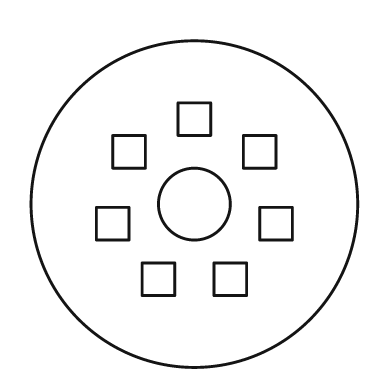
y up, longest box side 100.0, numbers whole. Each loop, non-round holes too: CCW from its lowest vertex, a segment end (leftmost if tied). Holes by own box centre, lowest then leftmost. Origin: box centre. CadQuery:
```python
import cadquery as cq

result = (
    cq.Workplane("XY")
    .moveTo(0.0, 0.0)
    .circle(50.0)
    .moveTo(-16.0, -28.0)
    .lineTo(-6.0, -28.0)
    .lineTo(-6.0, -18.0)
    .lineTo(-16.0, -18.0)
    .close()
    .moveTo(6.0, -28.0)
    .lineTo(16.0, -28.0)
    .lineTo(16.0, -18.0)
    .lineTo(6.0, -18.0)
    .close()
    .moveTo(-30.0, -11.0)
    .lineTo(-20.0, -11.0)
    .lineTo(-20.0, -1.0)
    .lineTo(-30.0, -1.0)
    .close()
    .moveTo(20.0, -11.0)
    .lineTo(30.0, -11.0)
    .lineTo(30.0, -1.0)
    .lineTo(20.0, -1.0)
    .close()
    .moveTo(0.0, 0.0)
    .circle(11.0)
    .moveTo(-25.0, 11.0)
    .lineTo(-15.0, 11.0)
    .lineTo(-15.0, 21.0)
    .lineTo(-25.0, 21.0)
    .close()
    .moveTo(15.0, 11.0)
    .lineTo(25.0, 11.0)
    .lineTo(25.0, 21.0)
    .lineTo(15.0, 21.0)
    .close()
    .moveTo(-5.0, 21.0)
    .lineTo(5.0, 21.0)
    .lineTo(5.0, 31.0)
    .lineTo(-5.0, 31.0)
    .close()
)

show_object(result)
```